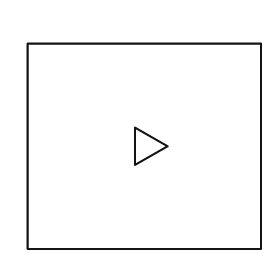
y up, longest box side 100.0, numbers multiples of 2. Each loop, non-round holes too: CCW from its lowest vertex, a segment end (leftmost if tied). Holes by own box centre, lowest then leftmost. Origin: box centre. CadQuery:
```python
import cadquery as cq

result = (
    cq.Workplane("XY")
    .moveTo(-50.0, -44.0)
    .lineTo(50.0, -44.0)
    .lineTo(50.0, 44.0)
    .lineTo(-50.0, 44.0)
    .close()
    .moveTo(-4.0, -8.0)
    .lineTo(10.0, 0.0)
    .lineTo(-4.0, 8.0)
    .close()
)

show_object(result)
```